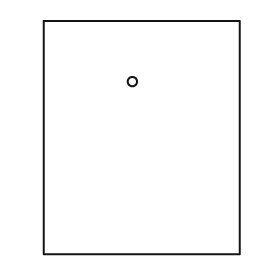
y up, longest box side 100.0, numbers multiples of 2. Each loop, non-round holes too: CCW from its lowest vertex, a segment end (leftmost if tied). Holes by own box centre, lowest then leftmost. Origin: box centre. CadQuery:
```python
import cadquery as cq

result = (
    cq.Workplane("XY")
    .moveTo(-42.0, -50.0)
    .lineTo(42.0, -50.0)
    .lineTo(42.0, 50.0)
    .lineTo(-42.0, 50.0)
    .close()
    .moveTo(-4.0, 24.0)
    .circle(2.0)
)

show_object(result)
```